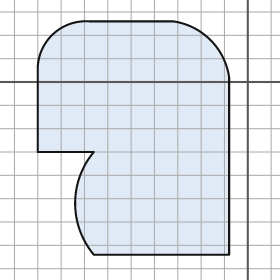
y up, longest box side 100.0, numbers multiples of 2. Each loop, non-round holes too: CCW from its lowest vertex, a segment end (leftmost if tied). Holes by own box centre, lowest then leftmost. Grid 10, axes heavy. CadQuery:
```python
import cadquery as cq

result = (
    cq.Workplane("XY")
    .moveTo(-66.0, -74.0)
    .lineTo(-8.0, -74.0)
    .lineTo(-8.0, 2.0)
    .threePointArc((-16.0, 18.0), (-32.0, 26.0))
    .lineTo(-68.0, 26.0)
    .threePointArc((-84.0, 20.0), (-90.0, 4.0))
    .lineTo(-90.0, -30.0)
    .lineTo(-66.0, -30.0)
    .threePointArc((-74.0, -52.0), (-66.0, -74.0))
    .close()
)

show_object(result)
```